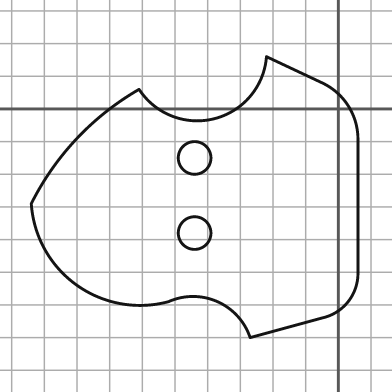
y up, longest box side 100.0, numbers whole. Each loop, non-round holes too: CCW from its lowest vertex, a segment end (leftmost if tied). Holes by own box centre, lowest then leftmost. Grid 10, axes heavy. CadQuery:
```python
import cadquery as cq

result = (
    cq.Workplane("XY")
    .moveTo(-27.0, -70.0)
    .lineTo(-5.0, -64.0)
    .threePointArc((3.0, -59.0), (6.0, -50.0))
    .lineTo(6.0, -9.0)
    .threePointArc((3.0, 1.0), (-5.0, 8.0))
    .lineTo(-22.0, 16.0)
    .threePointArc((-38.0, -3.0), (-61.0, 6.0))
    .threePointArc((-80.0, -9.0), (-94.0, -29.0))
    .threePointArc((-80.0, -54.0), (-52.0, -59.0))
    .threePointArc((-37.0, -59.0), (-27.0, -70.0))
    .close()
    .moveTo(-44.0, -38.0)
    .circle(5.0)
    .moveTo(-44.0, -15.0)
    .circle(5.0)
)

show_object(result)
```